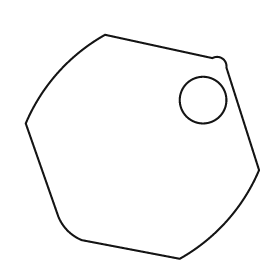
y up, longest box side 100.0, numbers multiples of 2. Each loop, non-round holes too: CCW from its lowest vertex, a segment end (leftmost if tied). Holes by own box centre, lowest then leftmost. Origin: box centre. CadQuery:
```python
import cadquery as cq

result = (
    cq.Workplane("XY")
    .moveTo(16.0, -48.0)
    .threePointArc((36.0, -32.0), (50.0, -10.0))
    .lineTo(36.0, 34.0)
    .threePointArc((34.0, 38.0), (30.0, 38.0))
    .lineTo(-16.0, 48.0)
    .threePointArc((-36.0, 32.0), (-50.0, 10.0))
    .lineTo(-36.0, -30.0)
    .threePointArc((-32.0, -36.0), (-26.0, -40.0))
    .close()
    .moveTo(26.0, 20.0)
    .circle(10.0)
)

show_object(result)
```